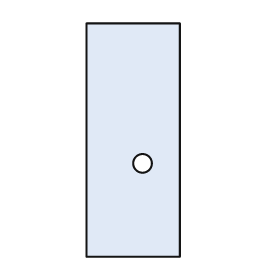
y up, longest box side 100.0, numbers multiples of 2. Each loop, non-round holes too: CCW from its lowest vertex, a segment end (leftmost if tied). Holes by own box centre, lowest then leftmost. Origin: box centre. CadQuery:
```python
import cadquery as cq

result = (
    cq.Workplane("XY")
    .moveTo(-20.0, -50.0)
    .lineTo(20.0, -50.0)
    .lineTo(20.0, 50.0)
    .lineTo(-20.0, 50.0)
    .close()
    .moveTo(4.0, -10.0)
    .circle(4.0)
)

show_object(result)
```